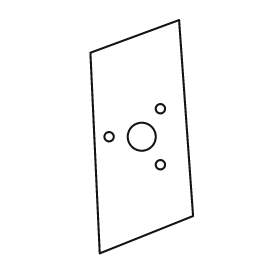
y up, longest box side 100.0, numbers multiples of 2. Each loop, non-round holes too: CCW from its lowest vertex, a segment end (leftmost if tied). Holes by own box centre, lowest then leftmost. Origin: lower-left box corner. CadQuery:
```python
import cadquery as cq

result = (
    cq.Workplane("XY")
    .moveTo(4.0, 0.0)
    .lineTo(44.0, 16.0)
    .lineTo(38.0, 100.0)
    .lineTo(0.0, 86.0)
    .close()
    .moveTo(30.0, 38.0)
    .circle(2.0)
    .moveTo(8.0, 50.0)
    .circle(2.0)
    .moveTo(22.0, 50.0)
    .circle(6.0)
    .moveTo(30.0, 62.0)
    .circle(2.0)
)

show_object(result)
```